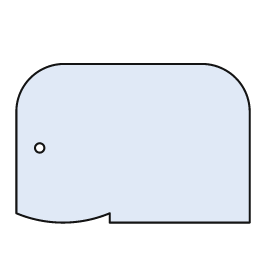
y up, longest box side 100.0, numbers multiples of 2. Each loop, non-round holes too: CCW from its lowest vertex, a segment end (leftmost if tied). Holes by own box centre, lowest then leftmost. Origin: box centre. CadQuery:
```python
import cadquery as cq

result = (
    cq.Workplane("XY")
    .moveTo(-10.0, -34.0)
    .lineTo(50.0, -34.0)
    .lineTo(50.0, 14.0)
    .threePointArc((44.0, 28.0), (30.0, 34.0))
    .lineTo(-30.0, 34.0)
    .threePointArc((-44.0, 28.0), (-50.0, 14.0))
    .lineTo(-50.0, -30.0)
    .threePointArc((-30.0, -34.0), (-10.0, -30.0))
    .close()
    .moveTo(-40.0, -2.0)
    .circle(2.0)
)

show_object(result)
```